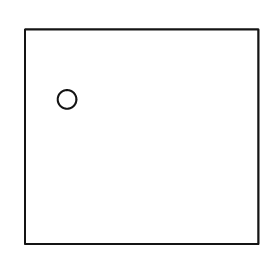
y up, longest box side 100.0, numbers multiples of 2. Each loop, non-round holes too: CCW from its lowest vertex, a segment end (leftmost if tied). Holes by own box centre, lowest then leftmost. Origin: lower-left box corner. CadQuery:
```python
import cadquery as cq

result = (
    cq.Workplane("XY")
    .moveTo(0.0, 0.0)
    .lineTo(100.0, 0.0)
    .lineTo(100.0, 92.0)
    .lineTo(0.0, 92.0)
    .close()
    .moveTo(18.0, 62.0)
    .circle(4.0)
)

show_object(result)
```